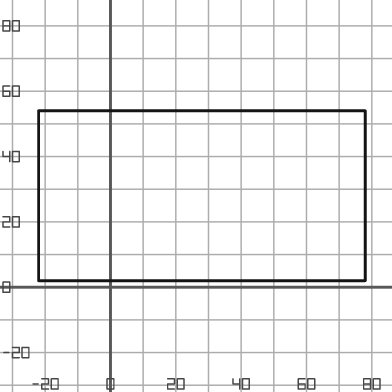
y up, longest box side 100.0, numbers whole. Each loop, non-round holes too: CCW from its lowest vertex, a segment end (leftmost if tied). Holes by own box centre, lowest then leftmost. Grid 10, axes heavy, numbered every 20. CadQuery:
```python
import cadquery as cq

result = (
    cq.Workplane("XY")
    .moveTo(-22.0, 2.0)
    .lineTo(78.0, 2.0)
    .lineTo(78.0, 54.0)
    .lineTo(-22.0, 54.0)
    .close()
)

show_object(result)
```